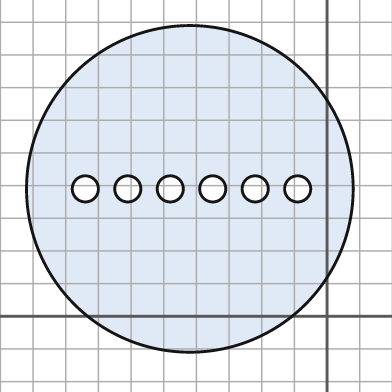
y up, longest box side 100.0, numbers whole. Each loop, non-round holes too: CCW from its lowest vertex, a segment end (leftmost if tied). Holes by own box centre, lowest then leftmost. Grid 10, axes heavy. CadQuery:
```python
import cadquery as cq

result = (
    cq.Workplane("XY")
    .moveTo(-42.0, 39.0)
    .circle(50.0)
    .moveTo(-74.0, 39.0)
    .circle(4.0)
    .moveTo(-61.0, 39.0)
    .circle(4.0)
    .moveTo(-48.0, 39.0)
    .circle(4.0)
    .moveTo(-35.0, 39.0)
    .circle(4.0)
    .moveTo(-22.0, 39.0)
    .circle(4.0)
    .moveTo(-9.0, 39.0)
    .circle(4.0)
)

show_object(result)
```